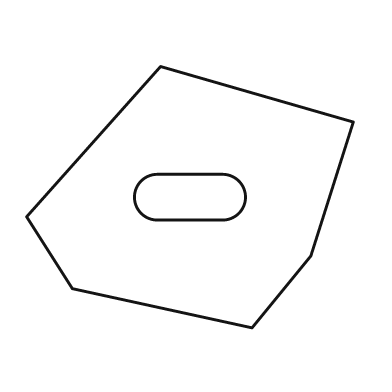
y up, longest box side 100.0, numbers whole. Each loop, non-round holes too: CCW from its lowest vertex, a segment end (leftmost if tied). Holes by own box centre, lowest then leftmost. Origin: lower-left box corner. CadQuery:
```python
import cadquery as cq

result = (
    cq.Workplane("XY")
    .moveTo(69.0, 0.0)
    .lineTo(87.0, 22.0)
    .lineTo(100.0, 63.0)
    .lineTo(41.0, 80.0)
    .lineTo(0.0, 34.0)
    .lineTo(14.0, 12.0)
    .close()
    .moveTo(40.0, 33.0)
    .lineTo(60.0, 33.0)
    .threePointArc((67.0, 40.0), (60.0, 47.0))
    .lineTo(40.0, 47.0)
    .threePointArc((33.0, 40.0), (40.0, 33.0))
    .close()
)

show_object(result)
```